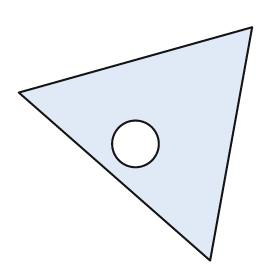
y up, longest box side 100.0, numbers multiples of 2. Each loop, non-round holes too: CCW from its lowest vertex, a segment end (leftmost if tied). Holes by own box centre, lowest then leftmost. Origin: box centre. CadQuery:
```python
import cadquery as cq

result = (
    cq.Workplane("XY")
    .moveTo(32.0, -50.0)
    .lineTo(50.0, 50.0)
    .lineTo(-50.0, 22.0)
    .close()
    .moveTo(0.0, 0.0)
    .circle(10.0)
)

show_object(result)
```